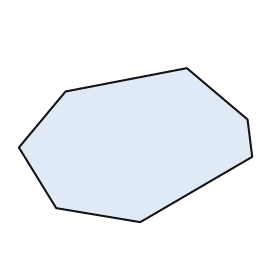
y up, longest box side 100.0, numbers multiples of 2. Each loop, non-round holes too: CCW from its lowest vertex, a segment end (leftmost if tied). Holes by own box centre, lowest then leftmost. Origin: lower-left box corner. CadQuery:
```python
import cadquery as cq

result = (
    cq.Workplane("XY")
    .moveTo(52.0, 0.0)
    .lineTo(100.0, 28.0)
    .lineTo(98.0, 44.0)
    .lineTo(72.0, 66.0)
    .lineTo(20.0, 56.0)
    .lineTo(0.0, 32.0)
    .lineTo(16.0, 6.0)
    .close()
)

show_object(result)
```